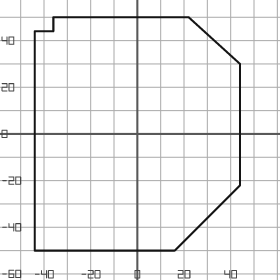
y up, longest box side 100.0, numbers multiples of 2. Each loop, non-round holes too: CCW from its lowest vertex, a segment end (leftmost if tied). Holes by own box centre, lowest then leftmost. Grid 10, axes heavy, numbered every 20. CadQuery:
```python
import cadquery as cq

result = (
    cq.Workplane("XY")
    .moveTo(-44.0, -50.0)
    .lineTo(16.0, -50.0)
    .lineTo(44.0, -22.0)
    .lineTo(44.0, 30.0)
    .lineTo(22.0, 50.0)
    .lineTo(-36.0, 50.0)
    .lineTo(-36.0, 44.0)
    .lineTo(-44.0, 44.0)
    .close()
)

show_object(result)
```